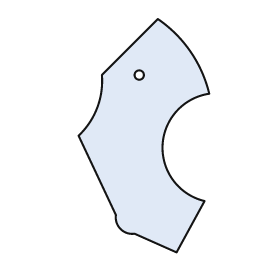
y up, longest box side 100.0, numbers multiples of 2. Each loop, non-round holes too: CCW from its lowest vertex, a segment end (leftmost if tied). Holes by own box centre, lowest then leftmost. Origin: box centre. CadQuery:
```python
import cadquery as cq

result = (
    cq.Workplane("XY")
    .moveTo(14.0, -50.0)
    .lineTo(26.0, -28.0)
    .threePointArc((8.0, -4.0), (28.0, 18.0))
    .threePointArc((20.0, 36.0), (6.0, 50.0))
    .lineTo(-18.0, 26.0)
    .threePointArc((-20.0, 12.0), (-28.0, 0.0))
    .lineTo(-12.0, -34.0)
    .threePointArc((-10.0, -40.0), (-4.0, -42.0))
    .close()
    .moveTo(-2.0, 26.0)
    .circle(2.0)
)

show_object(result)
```